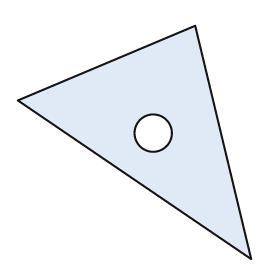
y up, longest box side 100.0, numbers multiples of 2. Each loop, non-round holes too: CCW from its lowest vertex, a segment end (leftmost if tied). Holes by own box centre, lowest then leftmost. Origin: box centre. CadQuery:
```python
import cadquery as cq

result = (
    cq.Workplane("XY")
    .moveTo(50.0, -50.0)
    .lineTo(26.0, 50.0)
    .lineTo(-50.0, 18.0)
    .close()
    .moveTo(8.0, 4.0)
    .circle(8.0)
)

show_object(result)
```